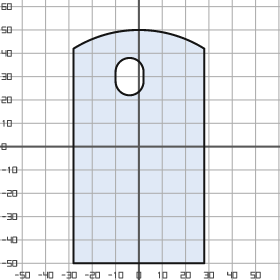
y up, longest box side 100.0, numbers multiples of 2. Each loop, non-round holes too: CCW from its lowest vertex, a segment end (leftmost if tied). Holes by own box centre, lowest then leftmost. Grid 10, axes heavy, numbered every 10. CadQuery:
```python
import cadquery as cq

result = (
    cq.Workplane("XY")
    .moveTo(-28.0, -50.0)
    .lineTo(28.0, -50.0)
    .lineTo(28.0, 42.0)
    .threePointArc((0.0, 50.0), (-28.0, 42.0))
    .close()
    .moveTo(-10.0, 28.0)
    .threePointArc((-4.0, 22.0), (2.0, 28.0))
    .lineTo(2.0, 32.0)
    .threePointArc((-4.0, 38.0), (-10.0, 32.0))
    .close()
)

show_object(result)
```